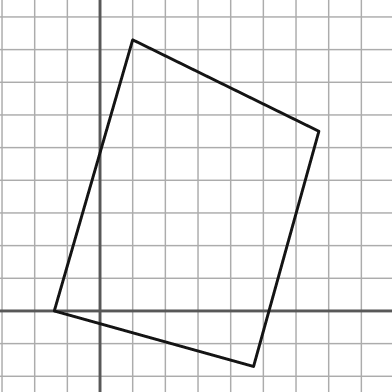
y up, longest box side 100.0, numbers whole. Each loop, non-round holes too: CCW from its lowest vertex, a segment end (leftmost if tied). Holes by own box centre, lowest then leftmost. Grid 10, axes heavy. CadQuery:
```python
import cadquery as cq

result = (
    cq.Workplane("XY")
    .moveTo(47.0, -17.0)
    .lineTo(67.0, 55.0)
    .lineTo(10.0, 83.0)
    .lineTo(-14.0, 0.0)
    .close()
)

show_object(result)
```